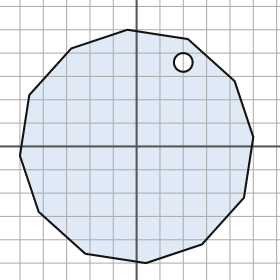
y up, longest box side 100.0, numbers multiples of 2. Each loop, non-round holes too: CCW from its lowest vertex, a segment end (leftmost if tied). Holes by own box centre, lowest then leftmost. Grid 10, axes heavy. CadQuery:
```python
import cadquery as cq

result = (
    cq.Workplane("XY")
    .moveTo(4.0, -50.0)
    .lineTo(28.0, -42.0)
    .lineTo(46.0, -22.0)
    .lineTo(50.0, 4.0)
    .lineTo(42.0, 28.0)
    .lineTo(22.0, 46.0)
    .lineTo(-4.0, 50.0)
    .lineTo(-28.0, 42.0)
    .lineTo(-46.0, 22.0)
    .lineTo(-50.0, -4.0)
    .lineTo(-42.0, -28.0)
    .lineTo(-22.0, -46.0)
    .close()
    .moveTo(20.0, 36.0)
    .circle(4.0)
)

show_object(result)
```